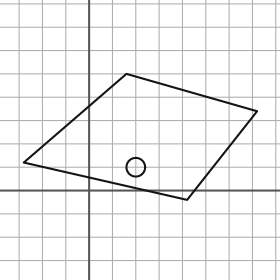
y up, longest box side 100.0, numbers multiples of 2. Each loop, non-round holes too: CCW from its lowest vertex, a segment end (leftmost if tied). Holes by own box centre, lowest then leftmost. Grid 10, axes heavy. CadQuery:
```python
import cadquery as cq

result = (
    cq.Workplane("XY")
    .moveTo(42.0, -4.0)
    .lineTo(72.0, 34.0)
    .lineTo(16.0, 50.0)
    .lineTo(-28.0, 12.0)
    .close()
    .moveTo(20.0, 10.0)
    .circle(4.0)
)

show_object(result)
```